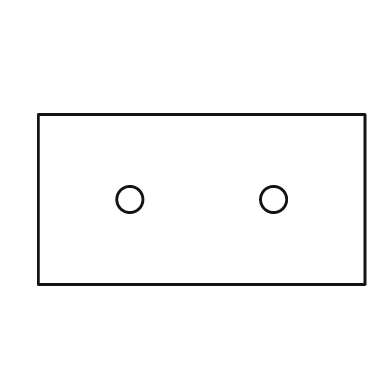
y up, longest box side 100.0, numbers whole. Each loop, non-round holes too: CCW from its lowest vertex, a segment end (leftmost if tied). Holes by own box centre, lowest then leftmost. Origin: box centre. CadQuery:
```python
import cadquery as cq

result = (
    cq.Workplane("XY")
    .moveTo(-50.0, -26.0)
    .lineTo(50.0, -26.0)
    .lineTo(50.0, 26.0)
    .lineTo(-50.0, 26.0)
    .close()
    .moveTo(-22.0, 0.0)
    .circle(4.0)
    .moveTo(22.0, 0.0)
    .circle(4.0)
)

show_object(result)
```